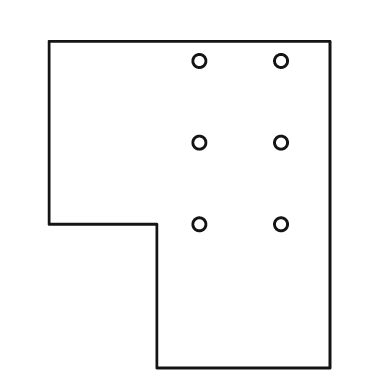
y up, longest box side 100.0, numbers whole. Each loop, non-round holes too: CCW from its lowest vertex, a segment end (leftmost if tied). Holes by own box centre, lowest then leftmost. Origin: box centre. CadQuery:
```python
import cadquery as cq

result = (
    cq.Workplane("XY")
    .moveTo(-10.0, -50.0)
    .lineTo(43.0, -50.0)
    .lineTo(43.0, 50.0)
    .lineTo(-43.0, 50.0)
    .lineTo(-43.0, -6.0)
    .lineTo(-10.0, -6.0)
    .close()
    .moveTo(3.0, -6.0)
    .circle(2.0)
    .moveTo(28.0, -6.0)
    .circle(2.0)
    .moveTo(3.0, 19.0)
    .circle(2.0)
    .moveTo(28.0, 19.0)
    .circle(2.0)
    .moveTo(3.0, 44.0)
    .circle(2.0)
    .moveTo(28.0, 44.0)
    .circle(2.0)
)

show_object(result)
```